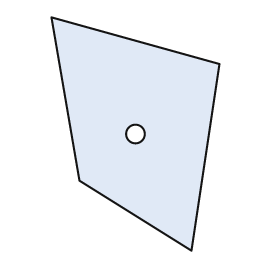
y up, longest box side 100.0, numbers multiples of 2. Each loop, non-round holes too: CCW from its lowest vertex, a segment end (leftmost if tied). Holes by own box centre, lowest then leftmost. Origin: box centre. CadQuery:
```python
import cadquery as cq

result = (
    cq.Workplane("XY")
    .moveTo(24.0, -50.0)
    .lineTo(36.0, 30.0)
    .lineTo(-36.0, 50.0)
    .lineTo(-24.0, -20.0)
    .close()
    .moveTo(0.0, 0.0)
    .circle(4.0)
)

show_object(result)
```